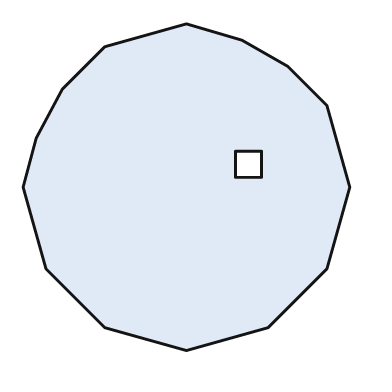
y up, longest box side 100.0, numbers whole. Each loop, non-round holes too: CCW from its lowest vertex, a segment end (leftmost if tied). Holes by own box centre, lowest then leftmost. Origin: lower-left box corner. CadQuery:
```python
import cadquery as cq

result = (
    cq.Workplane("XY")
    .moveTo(50.0, 0.0)
    .lineTo(75.0, 7.0)
    .lineTo(93.0, 25.0)
    .lineTo(100.0, 50.0)
    .lineTo(93.0, 75.0)
    .lineTo(81.0, 87.0)
    .lineTo(67.0, 95.0)
    .lineTo(50.0, 100.0)
    .lineTo(25.0, 93.0)
    .lineTo(12.0, 80.0)
    .lineTo(4.0, 65.0)
    .lineTo(0.0, 50.0)
    .lineTo(7.0, 25.0)
    .lineTo(25.0, 7.0)
    .close()
    .moveTo(65.0, 53.0)
    .lineTo(73.0, 53.0)
    .lineTo(73.0, 61.0)
    .lineTo(65.0, 61.0)
    .close()
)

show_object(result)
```